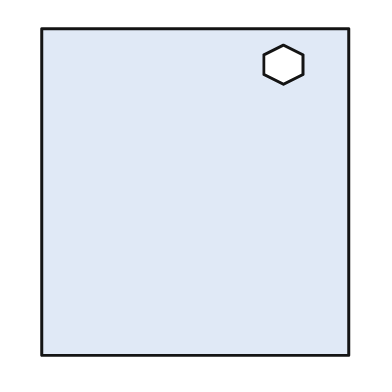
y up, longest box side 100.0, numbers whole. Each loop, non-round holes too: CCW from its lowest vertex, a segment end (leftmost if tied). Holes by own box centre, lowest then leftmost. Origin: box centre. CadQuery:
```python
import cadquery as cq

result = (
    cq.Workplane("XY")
    .moveTo(-47.0, -50.0)
    .lineTo(47.0, -50.0)
    .lineTo(47.0, 50.0)
    .lineTo(-47.0, 50.0)
    .close()
    .moveTo(27.0, 33.0)
    .lineTo(33.0, 36.0)
    .lineTo(33.0, 42.0)
    .lineTo(27.0, 45.0)
    .lineTo(21.0, 42.0)
    .lineTo(21.0, 36.0)
    .close()
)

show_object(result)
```